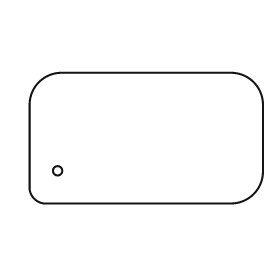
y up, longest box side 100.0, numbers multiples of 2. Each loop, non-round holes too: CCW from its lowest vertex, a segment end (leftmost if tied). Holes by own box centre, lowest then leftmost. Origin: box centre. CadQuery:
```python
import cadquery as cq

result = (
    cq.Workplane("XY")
    .moveTo(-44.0, -28.0)
    .lineTo(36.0, -28.0)
    .threePointArc((46.0, -24.0), (50.0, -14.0))
    .lineTo(50.0, 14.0)
    .threePointArc((46.0, 24.0), (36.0, 28.0))
    .lineTo(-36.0, 28.0)
    .threePointArc((-46.0, 24.0), (-50.0, 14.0))
    .lineTo(-50.0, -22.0)
    .threePointArc((-48.0, -26.0), (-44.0, -28.0))
    .close()
    .moveTo(-38.0, -14.0)
    .circle(2.0)
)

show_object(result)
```